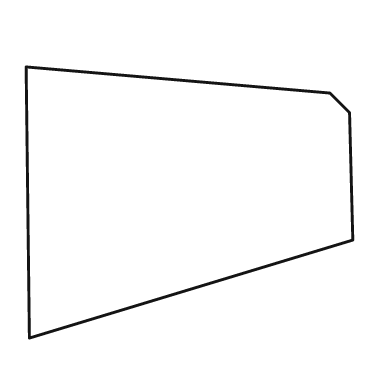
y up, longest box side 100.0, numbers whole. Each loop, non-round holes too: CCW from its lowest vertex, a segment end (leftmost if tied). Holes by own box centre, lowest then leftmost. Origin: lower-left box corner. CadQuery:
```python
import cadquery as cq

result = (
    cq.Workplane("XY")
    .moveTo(1.0, 0.0)
    .lineTo(100.0, 30.0)
    .lineTo(99.0, 69.0)
    .lineTo(93.0, 75.0)
    .lineTo(0.0, 83.0)
    .close()
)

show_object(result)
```